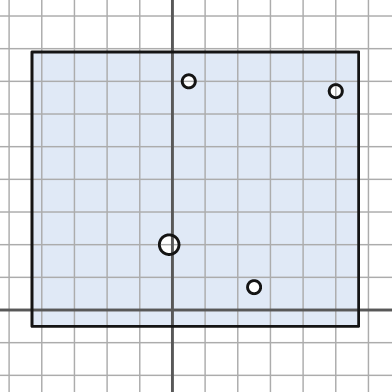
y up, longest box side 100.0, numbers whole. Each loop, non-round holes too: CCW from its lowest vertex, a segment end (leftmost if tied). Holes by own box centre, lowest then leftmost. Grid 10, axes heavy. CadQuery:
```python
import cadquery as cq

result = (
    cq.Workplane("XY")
    .moveTo(-43.0, -5.0)
    .lineTo(57.0, -5.0)
    .lineTo(57.0, 79.0)
    .lineTo(-43.0, 79.0)
    .close()
    .moveTo(25.0, 7.0)
    .circle(2.0)
    .moveTo(-1.0, 20.0)
    .circle(3.0)
    .moveTo(50.0, 67.0)
    .circle(2.0)
    .moveTo(5.0, 70.0)
    .circle(2.0)
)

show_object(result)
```